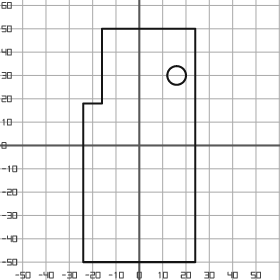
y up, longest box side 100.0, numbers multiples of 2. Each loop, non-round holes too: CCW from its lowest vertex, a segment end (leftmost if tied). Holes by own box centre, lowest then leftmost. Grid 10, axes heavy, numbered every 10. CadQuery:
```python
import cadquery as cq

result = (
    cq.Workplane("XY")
    .moveTo(-24.0, -50.0)
    .lineTo(24.0, -50.0)
    .lineTo(24.0, 50.0)
    .lineTo(-16.0, 50.0)
    .lineTo(-16.0, 18.0)
    .lineTo(-24.0, 18.0)
    .close()
    .moveTo(16.0, 30.0)
    .circle(4.0)
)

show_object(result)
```